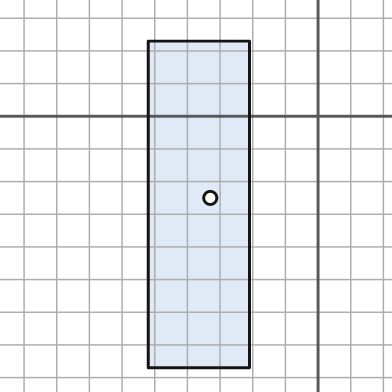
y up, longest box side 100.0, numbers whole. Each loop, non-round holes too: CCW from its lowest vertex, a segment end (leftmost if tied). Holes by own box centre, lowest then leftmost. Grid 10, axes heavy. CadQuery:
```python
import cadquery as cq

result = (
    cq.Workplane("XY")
    .moveTo(-52.0, -77.0)
    .lineTo(-21.0, -77.0)
    .lineTo(-21.0, 23.0)
    .lineTo(-52.0, 23.0)
    .close()
    .moveTo(-33.0, -25.0)
    .circle(2.0)
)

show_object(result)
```